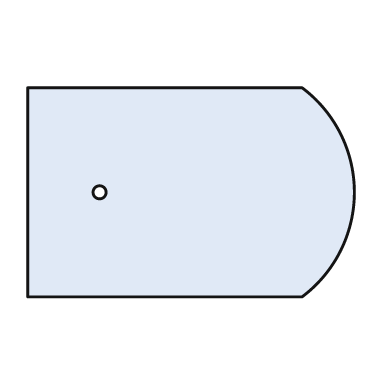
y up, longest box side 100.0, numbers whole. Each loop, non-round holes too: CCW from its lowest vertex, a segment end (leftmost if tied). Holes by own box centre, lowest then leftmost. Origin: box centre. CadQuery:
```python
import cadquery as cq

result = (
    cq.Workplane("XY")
    .moveTo(-50.0, -32.0)
    .lineTo(34.0, -32.0)
    .threePointArc((50.0, 0.0), (34.0, 32.0))
    .lineTo(-50.0, 32.0)
    .close()
    .moveTo(-28.0, 0.0)
    .circle(2.0)
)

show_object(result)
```